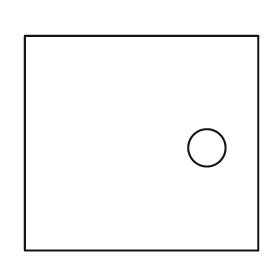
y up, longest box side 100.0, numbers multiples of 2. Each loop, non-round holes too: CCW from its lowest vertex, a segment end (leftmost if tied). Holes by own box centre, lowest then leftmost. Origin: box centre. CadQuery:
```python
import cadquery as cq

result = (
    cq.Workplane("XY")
    .moveTo(-50.0, -46.0)
    .lineTo(50.0, -46.0)
    .lineTo(50.0, 46.0)
    .lineTo(-50.0, 46.0)
    .close()
    .moveTo(28.0, -2.0)
    .circle(8.0)
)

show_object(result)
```